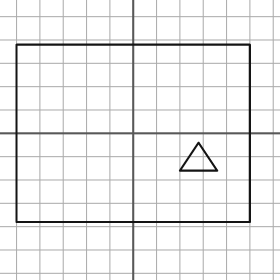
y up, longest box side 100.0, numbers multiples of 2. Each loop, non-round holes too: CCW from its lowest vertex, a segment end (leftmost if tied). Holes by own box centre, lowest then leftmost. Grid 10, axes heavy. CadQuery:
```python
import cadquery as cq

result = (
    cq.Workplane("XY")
    .moveTo(-50.0, -38.0)
    .lineTo(50.0, -38.0)
    .lineTo(50.0, 38.0)
    .lineTo(-50.0, 38.0)
    .close()
    .moveTo(20.0, -16.0)
    .lineTo(36.0, -16.0)
    .lineTo(28.0, -4.0)
    .close()
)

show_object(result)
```